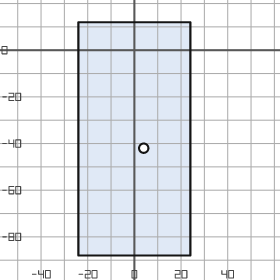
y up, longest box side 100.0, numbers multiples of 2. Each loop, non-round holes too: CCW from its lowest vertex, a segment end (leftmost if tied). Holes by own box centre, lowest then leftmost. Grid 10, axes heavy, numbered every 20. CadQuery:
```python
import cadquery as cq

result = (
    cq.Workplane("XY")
    .moveTo(-24.0, -88.0)
    .lineTo(24.0, -88.0)
    .lineTo(24.0, 12.0)
    .lineTo(-24.0, 12.0)
    .close()
    .moveTo(4.0, -42.0)
    .circle(2.0)
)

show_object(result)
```